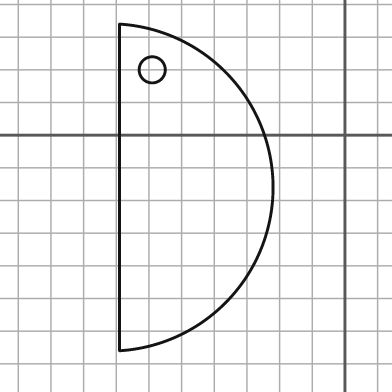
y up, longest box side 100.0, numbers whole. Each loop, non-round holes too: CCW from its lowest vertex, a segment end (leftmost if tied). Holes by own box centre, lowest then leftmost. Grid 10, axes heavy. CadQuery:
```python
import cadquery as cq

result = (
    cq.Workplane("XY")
    .moveTo(-69.0, -66.0)
    .threePointArc((-22.0, -16.0), (-69.0, 34.0))
    .close()
    .moveTo(-59.0, 20.0)
    .circle(4.0)
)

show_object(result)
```